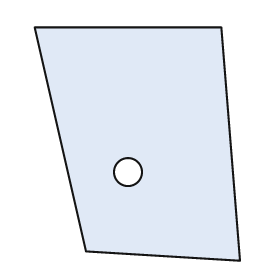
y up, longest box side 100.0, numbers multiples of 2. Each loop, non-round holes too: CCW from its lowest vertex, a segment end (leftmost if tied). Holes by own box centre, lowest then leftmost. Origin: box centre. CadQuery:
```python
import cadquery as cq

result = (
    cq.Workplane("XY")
    .moveTo(44.0, -50.0)
    .lineTo(36.0, 50.0)
    .lineTo(-44.0, 50.0)
    .lineTo(-22.0, -46.0)
    .close()
    .moveTo(-4.0, -12.0)
    .circle(6.0)
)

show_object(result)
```